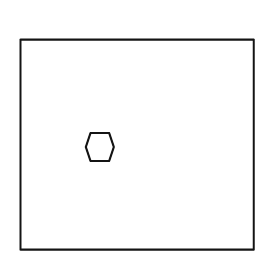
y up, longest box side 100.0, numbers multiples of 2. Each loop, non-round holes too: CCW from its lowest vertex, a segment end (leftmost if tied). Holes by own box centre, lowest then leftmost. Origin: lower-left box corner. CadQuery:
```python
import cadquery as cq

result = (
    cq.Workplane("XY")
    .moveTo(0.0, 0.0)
    .lineTo(100.0, 0.0)
    .lineTo(100.0, 90.0)
    .lineTo(0.0, 90.0)
    .close()
    .moveTo(30.0, 38.0)
    .lineTo(38.0, 38.0)
    .lineTo(40.0, 44.0)
    .lineTo(38.0, 50.0)
    .lineTo(30.0, 50.0)
    .lineTo(28.0, 44.0)
    .close()
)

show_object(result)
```